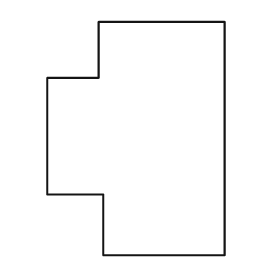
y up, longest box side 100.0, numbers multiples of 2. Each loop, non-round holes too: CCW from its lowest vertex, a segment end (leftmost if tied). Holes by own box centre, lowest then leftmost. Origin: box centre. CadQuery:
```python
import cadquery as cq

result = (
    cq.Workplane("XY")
    .moveTo(-14.0, -50.0)
    .lineTo(38.0, -50.0)
    .lineTo(38.0, 50.0)
    .lineTo(-16.0, 50.0)
    .lineTo(-16.0, 26.0)
    .lineTo(-38.0, 26.0)
    .lineTo(-38.0, -24.0)
    .lineTo(-14.0, -24.0)
    .close()
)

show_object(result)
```